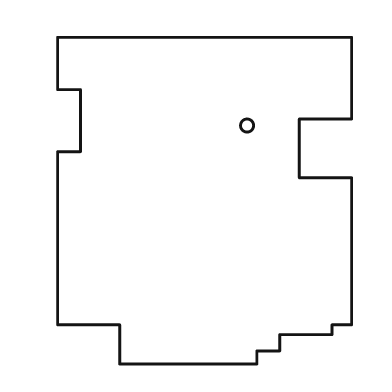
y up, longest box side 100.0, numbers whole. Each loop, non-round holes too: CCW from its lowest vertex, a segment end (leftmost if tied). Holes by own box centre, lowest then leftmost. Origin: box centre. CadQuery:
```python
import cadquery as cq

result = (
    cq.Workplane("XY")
    .moveTo(-26.0, -50.0)
    .lineTo(16.0, -50.0)
    .lineTo(16.0, -46.0)
    .lineTo(23.0, -46.0)
    .lineTo(23.0, -41.0)
    .lineTo(39.0, -41.0)
    .lineTo(39.0, -38.0)
    .lineTo(45.0, -38.0)
    .lineTo(45.0, 7.0)
    .lineTo(29.0, 7.0)
    .lineTo(29.0, 25.0)
    .lineTo(45.0, 25.0)
    .lineTo(45.0, 50.0)
    .lineTo(-45.0, 50.0)
    .lineTo(-45.0, 34.0)
    .lineTo(-38.0, 34.0)
    .lineTo(-38.0, 15.0)
    .lineTo(-45.0, 15.0)
    .lineTo(-45.0, -38.0)
    .lineTo(-26.0, -38.0)
    .close()
    .moveTo(13.0, 23.0)
    .circle(2.0)
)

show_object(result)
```